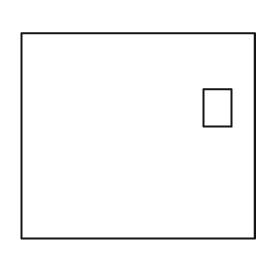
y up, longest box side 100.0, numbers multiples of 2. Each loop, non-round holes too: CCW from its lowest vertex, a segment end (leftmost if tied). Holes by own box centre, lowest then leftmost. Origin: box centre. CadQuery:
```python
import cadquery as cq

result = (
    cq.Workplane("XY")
    .moveTo(-50.0, -44.0)
    .lineTo(50.0, -44.0)
    .lineTo(50.0, 44.0)
    .lineTo(-50.0, 44.0)
    .close()
    .moveTo(28.0, 4.0)
    .lineTo(40.0, 4.0)
    .lineTo(40.0, 20.0)
    .lineTo(28.0, 20.0)
    .close()
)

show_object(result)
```